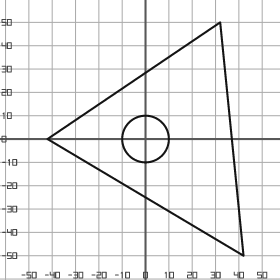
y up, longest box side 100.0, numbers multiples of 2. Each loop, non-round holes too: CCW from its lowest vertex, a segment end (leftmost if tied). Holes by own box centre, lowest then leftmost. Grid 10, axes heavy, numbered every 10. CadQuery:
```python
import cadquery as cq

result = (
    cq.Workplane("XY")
    .moveTo(42.0, -50.0)
    .lineTo(32.0, 50.0)
    .lineTo(-42.0, 0.0)
    .close()
    .moveTo(0.0, 0.0)
    .circle(10.0)
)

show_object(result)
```